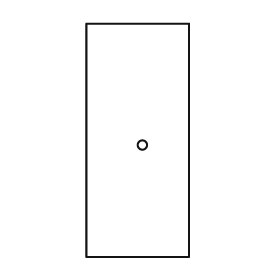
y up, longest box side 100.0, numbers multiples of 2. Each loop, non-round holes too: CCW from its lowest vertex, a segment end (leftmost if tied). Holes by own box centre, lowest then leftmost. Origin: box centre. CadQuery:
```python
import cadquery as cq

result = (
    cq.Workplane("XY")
    .moveTo(-22.0, -50.0)
    .lineTo(22.0, -50.0)
    .lineTo(22.0, 50.0)
    .lineTo(-22.0, 50.0)
    .close()
    .moveTo(2.0, -2.0)
    .circle(2.0)
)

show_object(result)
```